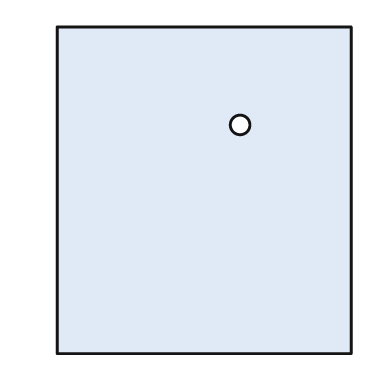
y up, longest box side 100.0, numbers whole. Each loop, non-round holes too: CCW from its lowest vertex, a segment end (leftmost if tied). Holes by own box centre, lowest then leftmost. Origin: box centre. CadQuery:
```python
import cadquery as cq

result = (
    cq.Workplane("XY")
    .moveTo(-45.0, -50.0)
    .lineTo(45.0, -50.0)
    .lineTo(45.0, 50.0)
    .lineTo(-45.0, 50.0)
    .close()
    .moveTo(11.0, 20.0)
    .circle(3.0)
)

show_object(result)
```